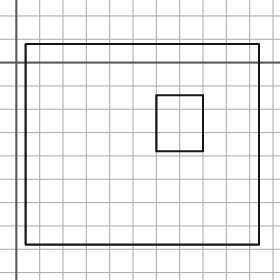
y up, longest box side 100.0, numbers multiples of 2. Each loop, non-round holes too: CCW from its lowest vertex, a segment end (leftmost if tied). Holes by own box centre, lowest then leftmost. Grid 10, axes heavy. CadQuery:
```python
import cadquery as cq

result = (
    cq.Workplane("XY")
    .moveTo(4.0, -78.0)
    .lineTo(104.0, -78.0)
    .lineTo(104.0, 8.0)
    .lineTo(4.0, 8.0)
    .close()
    .moveTo(60.0, -38.0)
    .lineTo(80.0, -38.0)
    .lineTo(80.0, -14.0)
    .lineTo(60.0, -14.0)
    .close()
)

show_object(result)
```